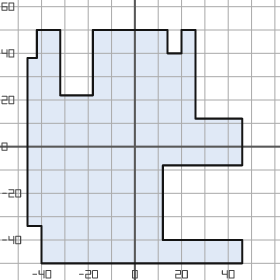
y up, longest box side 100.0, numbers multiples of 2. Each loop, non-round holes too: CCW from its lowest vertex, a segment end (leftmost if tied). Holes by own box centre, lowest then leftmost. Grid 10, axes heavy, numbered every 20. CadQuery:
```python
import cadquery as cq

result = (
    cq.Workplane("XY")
    .moveTo(-40.0, -50.0)
    .lineTo(46.0, -50.0)
    .lineTo(46.0, -40.0)
    .lineTo(12.0, -40.0)
    .lineTo(12.0, -8.0)
    .lineTo(46.0, -8.0)
    .lineTo(46.0, 12.0)
    .lineTo(26.0, 12.0)
    .lineTo(26.0, 50.0)
    .lineTo(20.0, 50.0)
    .lineTo(20.0, 40.0)
    .lineTo(14.0, 40.0)
    .lineTo(14.0, 50.0)
    .lineTo(-18.0, 50.0)
    .lineTo(-18.0, 22.0)
    .lineTo(-32.0, 22.0)
    .lineTo(-32.0, 50.0)
    .lineTo(-42.0, 50.0)
    .lineTo(-42.0, 38.0)
    .lineTo(-46.0, 38.0)
    .lineTo(-46.0, -34.0)
    .lineTo(-40.0, -34.0)
    .close()
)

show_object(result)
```